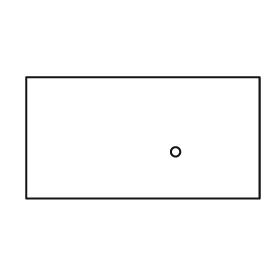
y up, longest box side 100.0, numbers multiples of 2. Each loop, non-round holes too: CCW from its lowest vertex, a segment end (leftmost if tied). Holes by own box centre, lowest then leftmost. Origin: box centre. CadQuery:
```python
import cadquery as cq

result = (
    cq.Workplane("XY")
    .moveTo(-50.0, -26.0)
    .lineTo(50.0, -26.0)
    .lineTo(50.0, 26.0)
    .lineTo(-50.0, 26.0)
    .close()
    .moveTo(14.0, -6.0)
    .circle(2.0)
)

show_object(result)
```